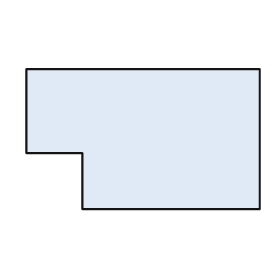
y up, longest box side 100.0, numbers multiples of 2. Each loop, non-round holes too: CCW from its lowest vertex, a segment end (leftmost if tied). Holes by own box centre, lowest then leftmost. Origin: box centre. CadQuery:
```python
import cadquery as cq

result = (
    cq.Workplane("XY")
    .moveTo(-26.0, -30.0)
    .lineTo(50.0, -30.0)
    .lineTo(50.0, 30.0)
    .lineTo(-50.0, 30.0)
    .lineTo(-50.0, -6.0)
    .lineTo(-26.0, -6.0)
    .close()
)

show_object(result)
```